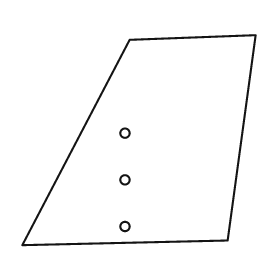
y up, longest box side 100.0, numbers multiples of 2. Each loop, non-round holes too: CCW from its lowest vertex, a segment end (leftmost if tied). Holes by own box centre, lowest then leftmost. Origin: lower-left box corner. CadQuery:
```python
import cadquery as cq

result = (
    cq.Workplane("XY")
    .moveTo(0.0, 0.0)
    .lineTo(88.0, 2.0)
    .lineTo(100.0, 90.0)
    .lineTo(46.0, 88.0)
    .close()
    .moveTo(44.0, 8.0)
    .circle(2.0)
    .moveTo(44.0, 28.0)
    .circle(2.0)
    .moveTo(44.0, 48.0)
    .circle(2.0)
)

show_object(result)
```